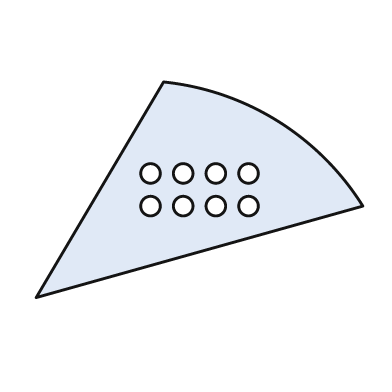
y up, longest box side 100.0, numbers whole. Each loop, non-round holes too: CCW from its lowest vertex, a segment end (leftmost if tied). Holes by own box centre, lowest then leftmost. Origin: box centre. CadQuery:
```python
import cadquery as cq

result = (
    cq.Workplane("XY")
    .moveTo(-50.0, -33.0)
    .lineTo(50.0, -5.0)
    .threePointArc((24.0, 21.0), (-11.0, 33.0))
    .close()
    .moveTo(-15.0, -5.0)
    .circle(3.0)
    .moveTo(-5.0, -5.0)
    .circle(3.0)
    .moveTo(5.0, -5.0)
    .circle(3.0)
    .moveTo(15.0, -5.0)
    .circle(3.0)
    .moveTo(-15.0, 5.0)
    .circle(3.0)
    .moveTo(-5.0, 5.0)
    .circle(3.0)
    .moveTo(5.0, 5.0)
    .circle(3.0)
    .moveTo(15.0, 5.0)
    .circle(3.0)
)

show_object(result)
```